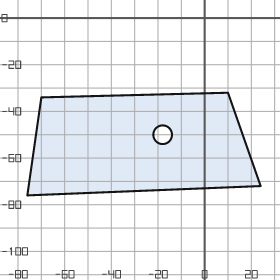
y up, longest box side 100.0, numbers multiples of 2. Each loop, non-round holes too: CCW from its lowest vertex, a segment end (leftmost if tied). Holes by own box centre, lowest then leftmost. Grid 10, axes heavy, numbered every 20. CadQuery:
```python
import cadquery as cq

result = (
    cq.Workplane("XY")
    .moveTo(-76.0, -76.0)
    .lineTo(24.0, -72.0)
    .lineTo(10.0, -32.0)
    .lineTo(-70.0, -34.0)
    .close()
    .moveTo(-18.0, -50.0)
    .circle(4.0)
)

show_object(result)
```